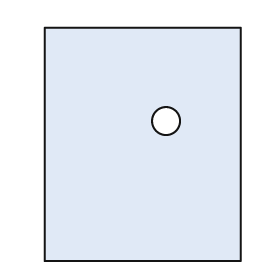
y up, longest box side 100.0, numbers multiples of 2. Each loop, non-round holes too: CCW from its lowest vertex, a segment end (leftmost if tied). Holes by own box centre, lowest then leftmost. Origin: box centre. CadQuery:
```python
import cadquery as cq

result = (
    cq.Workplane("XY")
    .moveTo(-42.0, -50.0)
    .lineTo(42.0, -50.0)
    .lineTo(42.0, 50.0)
    .lineTo(-42.0, 50.0)
    .close()
    .moveTo(10.0, 10.0)
    .circle(6.0)
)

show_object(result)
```